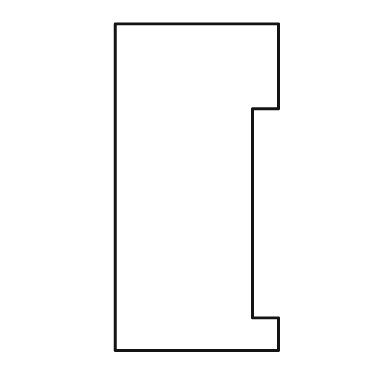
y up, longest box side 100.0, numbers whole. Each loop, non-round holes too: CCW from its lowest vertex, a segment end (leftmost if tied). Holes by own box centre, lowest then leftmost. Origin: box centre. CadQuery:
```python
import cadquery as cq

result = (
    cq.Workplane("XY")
    .moveTo(-25.0, -50.0)
    .lineTo(25.0, -50.0)
    .lineTo(25.0, -40.0)
    .lineTo(17.0, -40.0)
    .lineTo(17.0, 24.0)
    .lineTo(25.0, 24.0)
    .lineTo(25.0, 50.0)
    .lineTo(-25.0, 50.0)
    .close()
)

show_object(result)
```